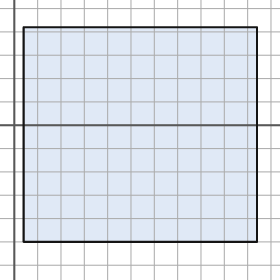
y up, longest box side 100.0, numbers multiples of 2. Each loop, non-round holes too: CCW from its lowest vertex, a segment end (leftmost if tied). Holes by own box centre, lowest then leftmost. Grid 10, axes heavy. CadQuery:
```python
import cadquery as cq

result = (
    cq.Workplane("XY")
    .moveTo(4.0, -50.0)
    .lineTo(104.0, -50.0)
    .lineTo(104.0, 42.0)
    .lineTo(4.0, 42.0)
    .close()
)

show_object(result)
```